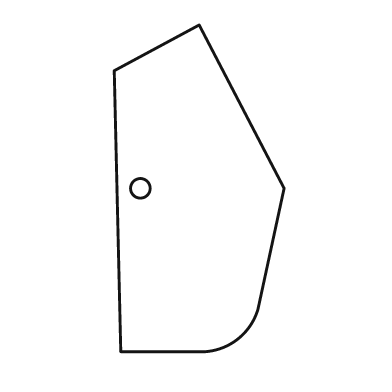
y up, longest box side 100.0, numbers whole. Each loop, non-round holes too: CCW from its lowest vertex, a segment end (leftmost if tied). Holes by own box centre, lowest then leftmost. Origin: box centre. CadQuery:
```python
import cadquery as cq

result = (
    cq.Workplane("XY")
    .moveTo(-24.0, -50.0)
    .lineTo(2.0, -50.0)
    .threePointArc((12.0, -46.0), (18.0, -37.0))
    .lineTo(26.0, 0.0)
    .lineTo(0.0, 50.0)
    .lineTo(-26.0, 36.0)
    .close()
    .moveTo(-18.0, 0.0)
    .circle(3.0)
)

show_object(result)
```